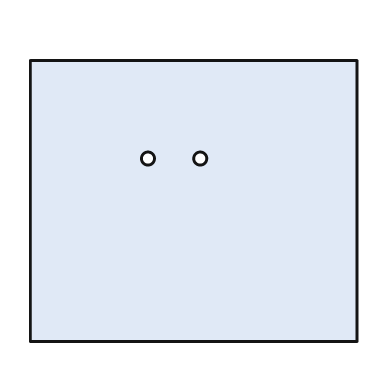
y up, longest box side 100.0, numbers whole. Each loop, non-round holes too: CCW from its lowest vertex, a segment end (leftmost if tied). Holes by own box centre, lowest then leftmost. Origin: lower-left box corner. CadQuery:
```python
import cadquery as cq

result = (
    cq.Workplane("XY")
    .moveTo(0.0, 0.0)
    .lineTo(100.0, 0.0)
    .lineTo(100.0, 86.0)
    .lineTo(0.0, 86.0)
    .close()
    .moveTo(36.0, 56.0)
    .circle(2.0)
    .moveTo(52.0, 56.0)
    .circle(2.0)
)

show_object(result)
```